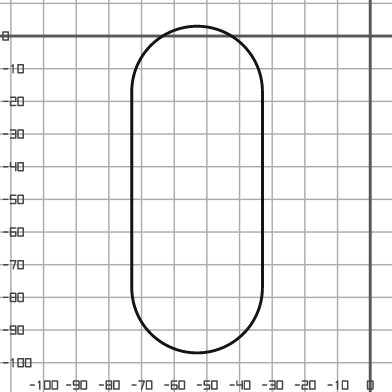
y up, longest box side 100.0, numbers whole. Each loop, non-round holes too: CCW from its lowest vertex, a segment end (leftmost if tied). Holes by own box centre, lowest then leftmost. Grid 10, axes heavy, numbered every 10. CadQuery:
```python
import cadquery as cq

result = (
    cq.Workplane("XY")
    .moveTo(-73.0, -77.0)
    .threePointArc((-53.0, -97.0), (-33.0, -77.0))
    .lineTo(-33.0, -17.0)
    .threePointArc((-53.0, 3.0), (-73.0, -17.0))
    .close()
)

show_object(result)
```